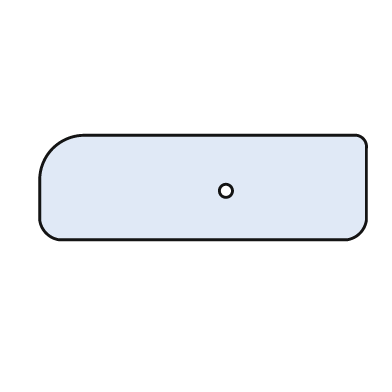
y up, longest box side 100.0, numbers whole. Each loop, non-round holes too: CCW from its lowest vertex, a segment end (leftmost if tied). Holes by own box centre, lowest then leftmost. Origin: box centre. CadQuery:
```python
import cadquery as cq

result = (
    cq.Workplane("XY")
    .moveTo(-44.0, -16.0)
    .lineTo(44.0, -16.0)
    .threePointArc((48.0, -14.0), (50.0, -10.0))
    .lineTo(50.0, 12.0)
    .threePointArc((49.0, 15.0), (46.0, 16.0))
    .lineTo(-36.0, 16.0)
    .threePointArc((-46.0, 12.0), (-50.0, 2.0))
    .lineTo(-50.0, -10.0)
    .threePointArc((-48.0, -14.0), (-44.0, -16.0))
    .close()
    .moveTo(7.0, -1.0)
    .circle(2.0)
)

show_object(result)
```